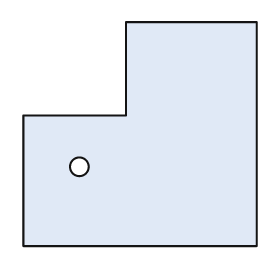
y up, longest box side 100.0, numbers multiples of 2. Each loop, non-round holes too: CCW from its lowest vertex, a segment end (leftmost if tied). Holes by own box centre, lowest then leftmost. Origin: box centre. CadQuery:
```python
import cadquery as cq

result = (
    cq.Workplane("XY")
    .moveTo(-50.0, -48.0)
    .lineTo(50.0, -48.0)
    .lineTo(50.0, 48.0)
    .lineTo(-6.0, 48.0)
    .lineTo(-6.0, 8.0)
    .lineTo(-50.0, 8.0)
    .close()
    .moveTo(-26.0, -14.0)
    .circle(4.0)
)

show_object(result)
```